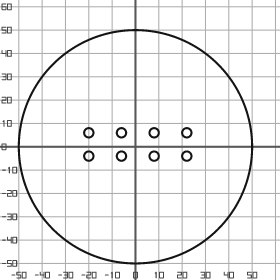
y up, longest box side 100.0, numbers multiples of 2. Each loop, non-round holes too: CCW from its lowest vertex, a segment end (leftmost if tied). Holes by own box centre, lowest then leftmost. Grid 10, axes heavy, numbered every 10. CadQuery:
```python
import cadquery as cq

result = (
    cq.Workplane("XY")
    .moveTo(0.0, 0.0)
    .circle(50.0)
    .moveTo(-20.0, -4.0)
    .circle(2.0)
    .moveTo(-6.0, -4.0)
    .circle(2.0)
    .moveTo(8.0, -4.0)
    .circle(2.0)
    .moveTo(22.0, -4.0)
    .circle(2.0)
    .moveTo(-20.0, 6.0)
    .circle(2.0)
    .moveTo(-6.0, 6.0)
    .circle(2.0)
    .moveTo(8.0, 6.0)
    .circle(2.0)
    .moveTo(22.0, 6.0)
    .circle(2.0)
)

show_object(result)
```